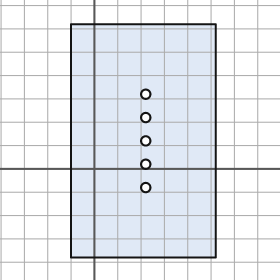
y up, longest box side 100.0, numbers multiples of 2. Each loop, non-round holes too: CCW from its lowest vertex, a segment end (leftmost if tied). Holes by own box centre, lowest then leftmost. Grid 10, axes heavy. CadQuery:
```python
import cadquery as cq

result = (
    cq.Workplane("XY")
    .moveTo(-10.0, -38.0)
    .lineTo(52.0, -38.0)
    .lineTo(52.0, 62.0)
    .lineTo(-10.0, 62.0)
    .close()
    .moveTo(22.0, -8.0)
    .circle(2.0)
    .moveTo(22.0, 2.0)
    .circle(2.0)
    .moveTo(22.0, 12.0)
    .circle(2.0)
    .moveTo(22.0, 22.0)
    .circle(2.0)
    .moveTo(22.0, 32.0)
    .circle(2.0)
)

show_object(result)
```